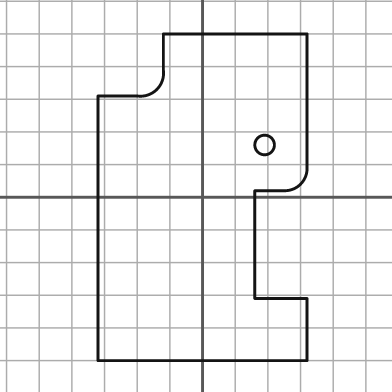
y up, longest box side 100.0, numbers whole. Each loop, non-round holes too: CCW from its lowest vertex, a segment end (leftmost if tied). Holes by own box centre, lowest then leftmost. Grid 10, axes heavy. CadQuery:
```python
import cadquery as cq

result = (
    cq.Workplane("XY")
    .moveTo(-32.0, -50.0)
    .lineTo(32.0, -50.0)
    .lineTo(32.0, -31.0)
    .lineTo(16.0, -31.0)
    .lineTo(16.0, 2.0)
    .lineTo(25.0, 2.0)
    .threePointArc((30.0, 4.0), (32.0, 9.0))
    .lineTo(32.0, 50.0)
    .lineTo(-12.0, 50.0)
    .lineTo(-12.0, 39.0)
    .threePointArc((-14.0, 33.0), (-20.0, 31.0))
    .lineTo(-32.0, 31.0)
    .close()
    .moveTo(19.0, 16.0)
    .circle(3.0)
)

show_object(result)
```